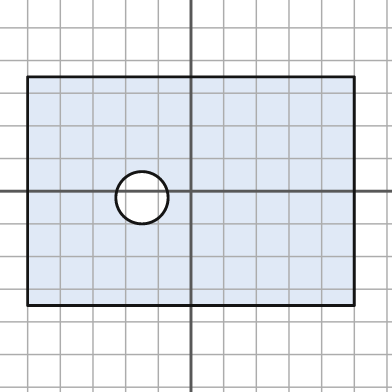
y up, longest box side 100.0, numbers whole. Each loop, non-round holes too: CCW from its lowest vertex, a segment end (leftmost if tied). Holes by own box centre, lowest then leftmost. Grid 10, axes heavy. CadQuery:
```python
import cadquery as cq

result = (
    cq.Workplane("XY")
    .moveTo(-50.0, -35.0)
    .lineTo(50.0, -35.0)
    .lineTo(50.0, 35.0)
    .lineTo(-50.0, 35.0)
    .close()
    .moveTo(-15.0, -2.0)
    .circle(8.0)
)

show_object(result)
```